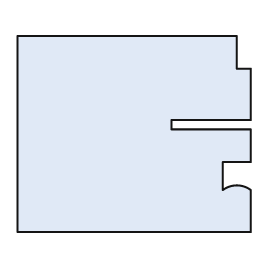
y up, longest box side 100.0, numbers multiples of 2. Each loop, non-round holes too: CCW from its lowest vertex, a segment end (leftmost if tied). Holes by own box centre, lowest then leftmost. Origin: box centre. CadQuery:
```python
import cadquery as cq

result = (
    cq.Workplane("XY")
    .moveTo(-50.0, -42.0)
    .lineTo(50.0, -42.0)
    .lineTo(50.0, -24.0)
    .threePointArc((44.0, -22.0), (38.0, -24.0))
    .lineTo(38.0, -12.0)
    .lineTo(50.0, -12.0)
    .lineTo(50.0, 2.0)
    .lineTo(16.0, 2.0)
    .lineTo(16.0, 6.0)
    .lineTo(50.0, 6.0)
    .lineTo(50.0, 28.0)
    .lineTo(44.0, 28.0)
    .lineTo(44.0, 42.0)
    .lineTo(-50.0, 42.0)
    .close()
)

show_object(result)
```